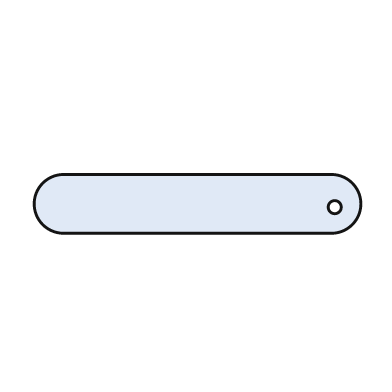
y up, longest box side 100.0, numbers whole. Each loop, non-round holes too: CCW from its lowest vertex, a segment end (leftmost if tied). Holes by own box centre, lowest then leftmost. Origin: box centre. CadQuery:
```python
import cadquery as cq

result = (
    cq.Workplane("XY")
    .moveTo(-41.0, -9.0)
    .lineTo(41.0, -9.0)
    .threePointArc((50.0, 0.0), (41.0, 9.0))
    .lineTo(-41.0, 9.0)
    .threePointArc((-50.0, 0.0), (-41.0, -9.0))
    .close()
    .moveTo(42.0, -1.0)
    .circle(2.0)
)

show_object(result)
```